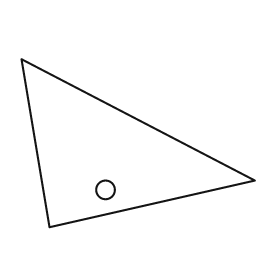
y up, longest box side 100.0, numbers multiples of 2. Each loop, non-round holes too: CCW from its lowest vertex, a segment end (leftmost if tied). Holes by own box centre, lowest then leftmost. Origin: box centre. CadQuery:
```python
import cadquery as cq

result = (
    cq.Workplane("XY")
    .moveTo(-38.0, -36.0)
    .lineTo(50.0, -16.0)
    .lineTo(-50.0, 36.0)
    .close()
    .moveTo(-14.0, -20.0)
    .circle(4.0)
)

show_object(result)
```